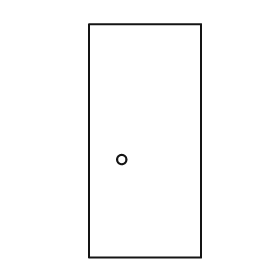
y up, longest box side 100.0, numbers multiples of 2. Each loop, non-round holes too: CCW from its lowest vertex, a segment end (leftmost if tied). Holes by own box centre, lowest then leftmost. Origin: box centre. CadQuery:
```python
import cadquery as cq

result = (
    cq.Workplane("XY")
    .moveTo(-24.0, -50.0)
    .lineTo(24.0, -50.0)
    .lineTo(24.0, 50.0)
    .lineTo(-24.0, 50.0)
    .close()
    .moveTo(-10.0, -8.0)
    .circle(2.0)
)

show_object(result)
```